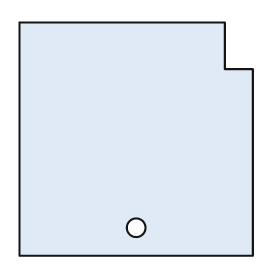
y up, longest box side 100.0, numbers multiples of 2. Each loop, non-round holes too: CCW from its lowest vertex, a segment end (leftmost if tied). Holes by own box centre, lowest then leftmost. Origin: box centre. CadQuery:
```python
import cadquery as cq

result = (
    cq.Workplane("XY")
    .moveTo(-50.0, -50.0)
    .lineTo(50.0, -50.0)
    .lineTo(50.0, 30.0)
    .lineTo(38.0, 30.0)
    .lineTo(38.0, 50.0)
    .lineTo(-50.0, 50.0)
    .close()
    .moveTo(0.0, -38.0)
    .circle(4.0)
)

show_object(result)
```